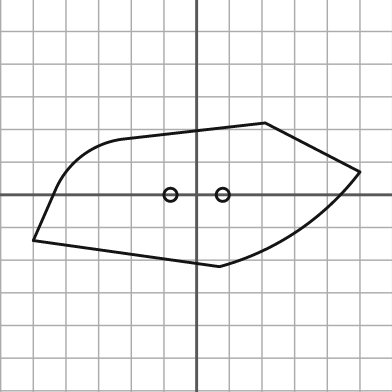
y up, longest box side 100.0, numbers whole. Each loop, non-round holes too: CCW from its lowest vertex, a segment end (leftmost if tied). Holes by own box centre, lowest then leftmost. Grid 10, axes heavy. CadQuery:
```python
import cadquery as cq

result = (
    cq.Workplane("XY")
    .moveTo(7.0, -22.0)
    .threePointArc((31.0, -11.0), (50.0, 7.0))
    .lineTo(21.0, 22.0)
    .lineTo(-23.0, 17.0)
    .threePointArc((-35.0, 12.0), (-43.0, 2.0))
    .lineTo(-50.0, -14.0)
    .close()
    .moveTo(-8.0, 0.0)
    .circle(2.0)
    .moveTo(8.0, 0.0)
    .circle(2.0)
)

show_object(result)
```